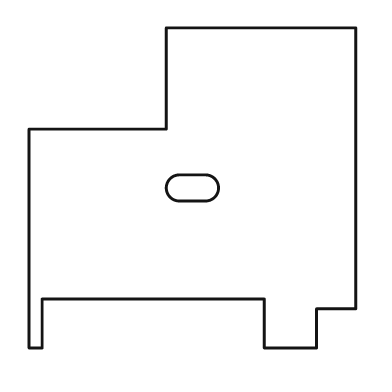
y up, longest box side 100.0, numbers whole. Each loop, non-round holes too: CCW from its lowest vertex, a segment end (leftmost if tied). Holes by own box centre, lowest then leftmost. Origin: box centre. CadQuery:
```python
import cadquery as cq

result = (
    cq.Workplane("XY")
    .moveTo(-50.0, -49.0)
    .lineTo(-46.0, -49.0)
    .lineTo(-46.0, -34.0)
    .lineTo(22.0, -34.0)
    .lineTo(22.0, -49.0)
    .lineTo(38.0, -49.0)
    .lineTo(38.0, -37.0)
    .lineTo(50.0, -37.0)
    .lineTo(50.0, 49.0)
    .lineTo(-8.0, 49.0)
    .lineTo(-8.0, 18.0)
    .lineTo(-50.0, 18.0)
    .close()
    .moveTo(-4.0, -4.0)
    .lineTo(4.0, -4.0)
    .threePointArc((8.0, 0.0), (4.0, 4.0))
    .lineTo(-4.0, 4.0)
    .threePointArc((-8.0, 0.0), (-4.0, -4.0))
    .close()
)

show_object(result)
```